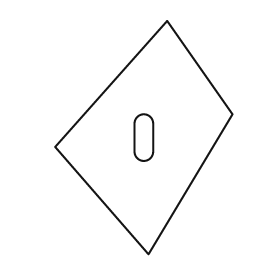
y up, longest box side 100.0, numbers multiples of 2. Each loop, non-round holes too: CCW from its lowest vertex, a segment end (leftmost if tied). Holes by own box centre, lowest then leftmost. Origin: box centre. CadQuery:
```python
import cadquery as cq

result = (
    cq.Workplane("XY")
    .moveTo(2.0, -50.0)
    .lineTo(38.0, 10.0)
    .lineTo(10.0, 50.0)
    .lineTo(-38.0, -4.0)
    .close()
    .moveTo(-4.0, -6.0)
    .threePointArc((0.0, -10.0), (4.0, -6.0))
    .lineTo(4.0, 6.0)
    .threePointArc((0.0, 10.0), (-4.0, 6.0))
    .close()
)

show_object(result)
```